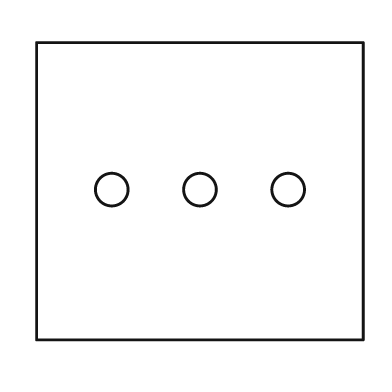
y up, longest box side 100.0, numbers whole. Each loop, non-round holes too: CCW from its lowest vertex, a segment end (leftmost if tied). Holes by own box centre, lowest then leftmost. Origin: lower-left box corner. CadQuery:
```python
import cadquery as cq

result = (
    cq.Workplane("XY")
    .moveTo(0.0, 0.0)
    .lineTo(100.0, 0.0)
    .lineTo(100.0, 91.0)
    .lineTo(0.0, 91.0)
    .close()
    .moveTo(23.0, 46.0)
    .circle(5.0)
    .moveTo(50.0, 46.0)
    .circle(5.0)
    .moveTo(77.0, 46.0)
    .circle(5.0)
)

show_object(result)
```